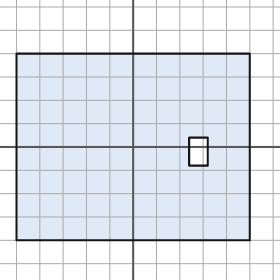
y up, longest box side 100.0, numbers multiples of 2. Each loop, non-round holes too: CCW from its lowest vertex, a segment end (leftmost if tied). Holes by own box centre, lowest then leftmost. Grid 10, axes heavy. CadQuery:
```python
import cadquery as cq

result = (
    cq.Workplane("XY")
    .moveTo(-50.0, -40.0)
    .lineTo(50.0, -40.0)
    .lineTo(50.0, 40.0)
    .lineTo(-50.0, 40.0)
    .close()
    .moveTo(24.0, -8.0)
    .lineTo(32.0, -8.0)
    .lineTo(32.0, 4.0)
    .lineTo(24.0, 4.0)
    .close()
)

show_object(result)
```